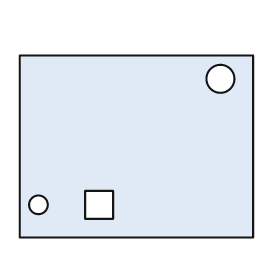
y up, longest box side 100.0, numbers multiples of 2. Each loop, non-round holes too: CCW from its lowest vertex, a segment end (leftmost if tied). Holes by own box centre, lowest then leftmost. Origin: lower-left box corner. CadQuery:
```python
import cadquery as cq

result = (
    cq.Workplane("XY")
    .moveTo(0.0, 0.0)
    .lineTo(100.0, 0.0)
    .lineTo(100.0, 78.0)
    .lineTo(0.0, 78.0)
    .close()
    .moveTo(8.0, 14.0)
    .circle(4.0)
    .moveTo(28.0, 8.0)
    .lineTo(40.0, 8.0)
    .lineTo(40.0, 20.0)
    .lineTo(28.0, 20.0)
    .close()
    .moveTo(86.0, 68.0)
    .circle(6.0)
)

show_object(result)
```